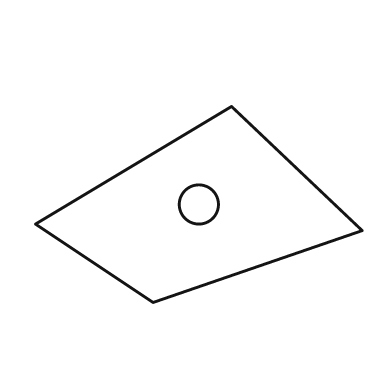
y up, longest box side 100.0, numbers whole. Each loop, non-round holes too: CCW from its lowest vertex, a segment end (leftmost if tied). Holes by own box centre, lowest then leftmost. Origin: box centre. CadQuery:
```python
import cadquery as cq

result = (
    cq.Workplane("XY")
    .moveTo(-14.0, -30.0)
    .lineTo(50.0, -8.0)
    .lineTo(10.0, 30.0)
    .lineTo(-50.0, -6.0)
    .close()
    .moveTo(0.0, 0.0)
    .circle(6.0)
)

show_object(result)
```